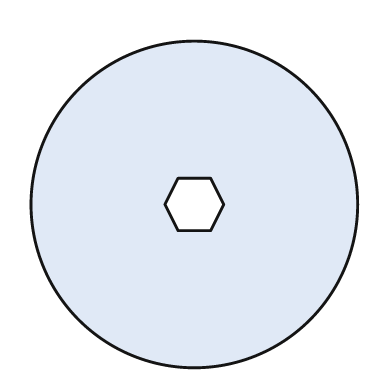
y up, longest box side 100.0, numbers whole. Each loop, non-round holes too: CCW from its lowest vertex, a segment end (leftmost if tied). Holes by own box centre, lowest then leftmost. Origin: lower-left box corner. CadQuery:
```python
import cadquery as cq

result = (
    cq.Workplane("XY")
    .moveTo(50.0, 50.0)
    .circle(50.0)
    .moveTo(45.0, 42.0)
    .lineTo(55.0, 42.0)
    .lineTo(59.0, 50.0)
    .lineTo(55.0, 58.0)
    .lineTo(45.0, 58.0)
    .lineTo(41.0, 50.0)
    .close()
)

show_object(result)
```